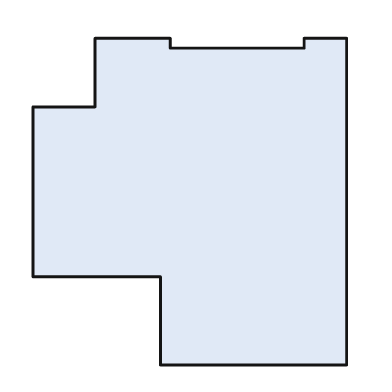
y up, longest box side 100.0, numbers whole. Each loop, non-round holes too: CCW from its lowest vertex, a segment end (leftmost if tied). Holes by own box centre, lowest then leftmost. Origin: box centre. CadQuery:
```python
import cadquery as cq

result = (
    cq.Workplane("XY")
    .moveTo(-9.0, -50.0)
    .lineTo(48.0, -50.0)
    .lineTo(48.0, 50.0)
    .lineTo(35.0, 50.0)
    .lineTo(35.0, 47.0)
    .lineTo(-6.0, 47.0)
    .lineTo(-6.0, 50.0)
    .lineTo(-29.0, 50.0)
    .lineTo(-29.0, 29.0)
    .lineTo(-48.0, 29.0)
    .lineTo(-48.0, -23.0)
    .lineTo(-9.0, -23.0)
    .close()
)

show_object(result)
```